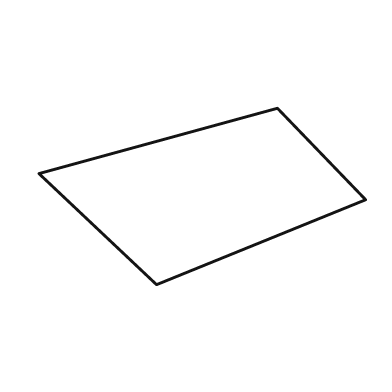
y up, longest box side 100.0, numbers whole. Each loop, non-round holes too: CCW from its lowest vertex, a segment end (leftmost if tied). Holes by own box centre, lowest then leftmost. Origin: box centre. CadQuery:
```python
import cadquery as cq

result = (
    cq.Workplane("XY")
    .moveTo(-14.0, -27.0)
    .lineTo(50.0, -1.0)
    .lineTo(23.0, 27.0)
    .lineTo(-50.0, 7.0)
    .close()
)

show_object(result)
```